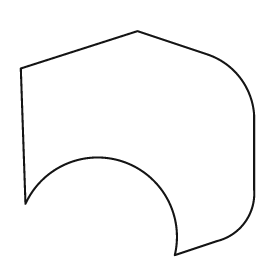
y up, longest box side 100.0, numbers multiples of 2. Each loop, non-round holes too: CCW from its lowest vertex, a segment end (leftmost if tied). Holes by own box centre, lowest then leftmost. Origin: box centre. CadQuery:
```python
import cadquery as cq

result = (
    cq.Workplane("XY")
    .moveTo(16.0, -48.0)
    .lineTo(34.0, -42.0)
    .threePointArc((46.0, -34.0), (50.0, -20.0))
    .lineTo(50.0, 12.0)
    .threePointArc((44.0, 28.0), (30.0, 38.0))
    .lineTo(0.0, 48.0)
    .lineTo(-50.0, 32.0)
    .lineTo(-48.0, -26.0)
    .threePointArc((-6.0, -8.0), (16.0, -48.0))
    .close()
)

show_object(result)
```